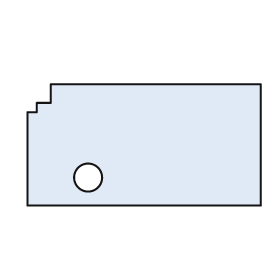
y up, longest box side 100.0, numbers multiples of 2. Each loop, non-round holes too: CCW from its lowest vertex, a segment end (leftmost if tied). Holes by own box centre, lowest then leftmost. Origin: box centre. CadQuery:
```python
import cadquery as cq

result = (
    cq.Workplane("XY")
    .moveTo(-50.0, -26.0)
    .lineTo(50.0, -26.0)
    .lineTo(50.0, 26.0)
    .lineTo(-40.0, 26.0)
    .lineTo(-40.0, 18.0)
    .lineTo(-46.0, 18.0)
    .lineTo(-46.0, 14.0)
    .lineTo(-50.0, 14.0)
    .close()
    .moveTo(-24.0, -14.0)
    .circle(6.0)
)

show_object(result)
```